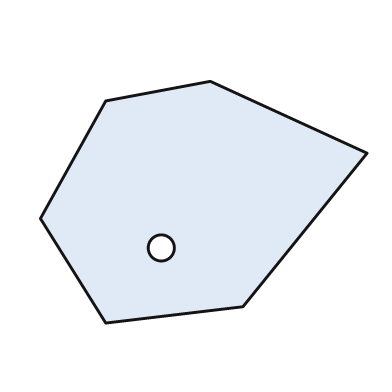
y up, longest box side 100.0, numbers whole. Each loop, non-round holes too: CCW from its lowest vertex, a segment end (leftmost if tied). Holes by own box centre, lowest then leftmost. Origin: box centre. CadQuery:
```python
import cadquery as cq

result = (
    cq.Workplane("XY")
    .moveTo(-30.0, -37.0)
    .lineTo(12.0, -32.0)
    .lineTo(50.0, 15.0)
    .lineTo(2.0, 37.0)
    .lineTo(-30.0, 31.0)
    .lineTo(-50.0, -5.0)
    .close()
    .moveTo(-13.0, -14.0)
    .circle(4.0)
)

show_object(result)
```